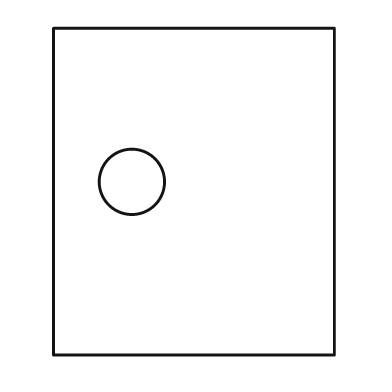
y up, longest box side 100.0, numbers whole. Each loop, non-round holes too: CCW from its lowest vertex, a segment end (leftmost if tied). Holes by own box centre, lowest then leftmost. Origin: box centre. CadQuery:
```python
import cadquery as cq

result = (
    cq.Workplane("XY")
    .moveTo(-43.0, -50.0)
    .lineTo(43.0, -50.0)
    .lineTo(43.0, 50.0)
    .lineTo(-43.0, 50.0)
    .close()
    .moveTo(-19.0, 3.0)
    .circle(10.0)
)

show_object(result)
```